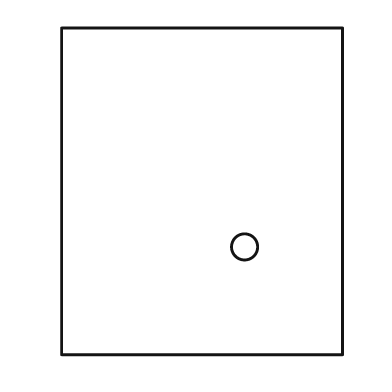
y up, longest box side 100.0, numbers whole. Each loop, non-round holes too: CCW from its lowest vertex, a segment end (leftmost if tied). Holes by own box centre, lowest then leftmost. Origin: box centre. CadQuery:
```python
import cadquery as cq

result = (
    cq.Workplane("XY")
    .moveTo(-43.0, -50.0)
    .lineTo(43.0, -50.0)
    .lineTo(43.0, 50.0)
    .lineTo(-43.0, 50.0)
    .close()
    .moveTo(13.0, -17.0)
    .circle(4.0)
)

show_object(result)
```